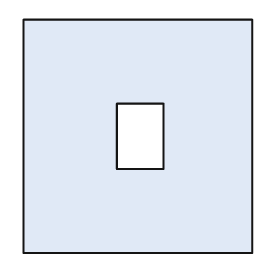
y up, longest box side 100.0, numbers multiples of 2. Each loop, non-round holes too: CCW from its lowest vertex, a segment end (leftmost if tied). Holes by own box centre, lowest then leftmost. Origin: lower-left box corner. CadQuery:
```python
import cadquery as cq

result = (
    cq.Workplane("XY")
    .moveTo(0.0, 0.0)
    .lineTo(98.0, 0.0)
    .lineTo(98.0, 100.0)
    .lineTo(0.0, 100.0)
    .close()
    .moveTo(40.0, 36.0)
    .lineTo(60.0, 36.0)
    .lineTo(60.0, 64.0)
    .lineTo(40.0, 64.0)
    .close()
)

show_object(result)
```